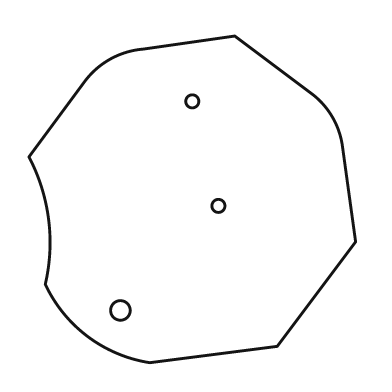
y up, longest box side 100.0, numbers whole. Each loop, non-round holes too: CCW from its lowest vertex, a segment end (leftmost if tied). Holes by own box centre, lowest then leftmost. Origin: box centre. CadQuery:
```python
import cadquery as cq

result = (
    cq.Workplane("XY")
    .moveTo(-13.0, -50.0)
    .lineTo(26.0, -45.0)
    .lineTo(50.0, -13.0)
    .lineTo(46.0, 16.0)
    .threePointArc((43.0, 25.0), (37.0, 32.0))
    .lineTo(13.0, 50.0)
    .lineTo(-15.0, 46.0)
    .threePointArc((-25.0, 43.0), (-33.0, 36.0))
    .lineTo(-50.0, 13.0)
    .threePointArc((-44.0, -6.0), (-45.0, -26.0))
    .threePointArc((-32.0, -42.0), (-13.0, -50.0))
    .close()
    .moveTo(-22.0, -34.0)
    .circle(3.0)
    .moveTo(8.0, -2.0)
    .circle(2.0)
    .moveTo(0.0, 30.0)
    .circle(2.0)
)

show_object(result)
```